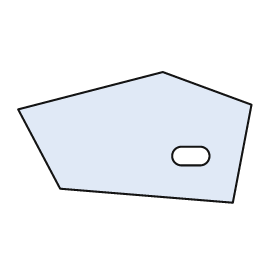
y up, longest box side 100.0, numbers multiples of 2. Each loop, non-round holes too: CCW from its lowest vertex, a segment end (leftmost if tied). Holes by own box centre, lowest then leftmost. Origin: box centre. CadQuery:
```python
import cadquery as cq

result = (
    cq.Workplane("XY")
    .moveTo(42.0, -28.0)
    .lineTo(50.0, 14.0)
    .lineTo(12.0, 28.0)
    .lineTo(-50.0, 12.0)
    .lineTo(-32.0, -22.0)
    .close()
    .moveTo(20.0, -12.0)
    .lineTo(28.0, -12.0)
    .threePointArc((32.0, -8.0), (28.0, -4.0))
    .lineTo(20.0, -4.0)
    .threePointArc((16.0, -8.0), (20.0, -12.0))
    .close()
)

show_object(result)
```